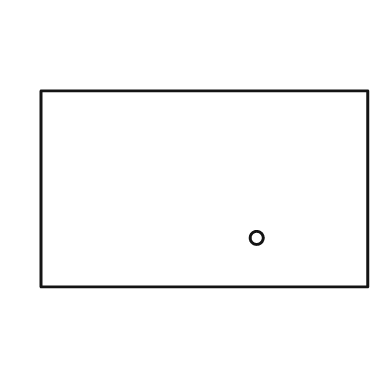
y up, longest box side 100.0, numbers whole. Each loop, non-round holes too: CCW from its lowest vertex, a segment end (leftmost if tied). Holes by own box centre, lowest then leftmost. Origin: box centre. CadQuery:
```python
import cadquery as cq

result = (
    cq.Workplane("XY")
    .moveTo(-50.0, -30.0)
    .lineTo(50.0, -30.0)
    .lineTo(50.0, 30.0)
    .lineTo(-50.0, 30.0)
    .close()
    .moveTo(16.0, -15.0)
    .circle(2.0)
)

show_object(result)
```